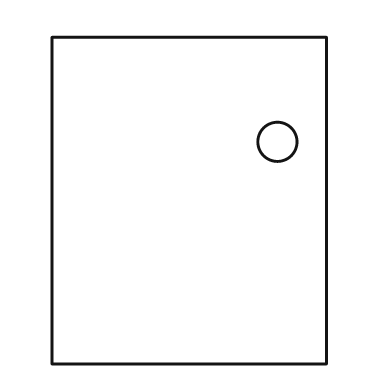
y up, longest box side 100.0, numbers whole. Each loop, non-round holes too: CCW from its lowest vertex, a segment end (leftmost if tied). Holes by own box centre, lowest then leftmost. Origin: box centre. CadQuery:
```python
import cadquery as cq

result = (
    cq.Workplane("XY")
    .moveTo(-42.0, -50.0)
    .lineTo(42.0, -50.0)
    .lineTo(42.0, 50.0)
    .lineTo(-42.0, 50.0)
    .close()
    .moveTo(27.0, 18.0)
    .circle(6.0)
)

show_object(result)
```